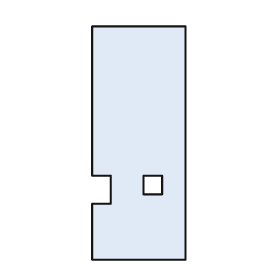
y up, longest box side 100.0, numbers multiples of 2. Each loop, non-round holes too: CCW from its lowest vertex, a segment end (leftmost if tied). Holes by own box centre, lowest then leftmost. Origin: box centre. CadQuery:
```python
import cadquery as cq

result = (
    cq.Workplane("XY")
    .moveTo(-20.0, -50.0)
    .lineTo(20.0, -50.0)
    .lineTo(20.0, 50.0)
    .lineTo(-20.0, 50.0)
    .lineTo(-20.0, -14.0)
    .lineTo(-12.0, -14.0)
    .lineTo(-12.0, -26.0)
    .lineTo(-20.0, -26.0)
    .close()
    .moveTo(2.0, -22.0)
    .lineTo(10.0, -22.0)
    .lineTo(10.0, -14.0)
    .lineTo(2.0, -14.0)
    .close()
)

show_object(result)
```